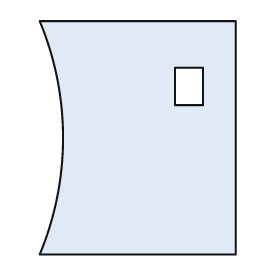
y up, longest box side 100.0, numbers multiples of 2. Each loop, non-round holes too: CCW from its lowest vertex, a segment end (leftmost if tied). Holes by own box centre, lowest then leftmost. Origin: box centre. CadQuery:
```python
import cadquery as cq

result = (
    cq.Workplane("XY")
    .moveTo(-42.0, -50.0)
    .lineTo(42.0, -50.0)
    .lineTo(42.0, 50.0)
    .lineTo(-42.0, 50.0)
    .threePointArc((-32.0, 0.0), (-42.0, -50.0))
    .close()
    .moveTo(16.0, 14.0)
    .lineTo(28.0, 14.0)
    .lineTo(28.0, 30.0)
    .lineTo(16.0, 30.0)
    .close()
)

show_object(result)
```